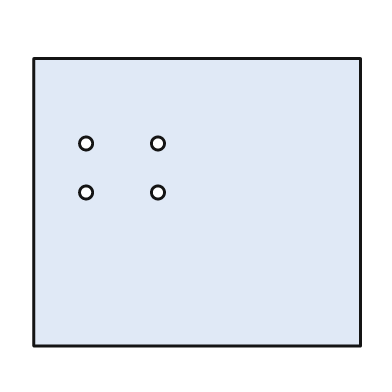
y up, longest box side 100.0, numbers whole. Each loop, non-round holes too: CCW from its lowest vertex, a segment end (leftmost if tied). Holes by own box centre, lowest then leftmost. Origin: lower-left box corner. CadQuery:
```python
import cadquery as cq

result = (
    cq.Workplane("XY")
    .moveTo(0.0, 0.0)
    .lineTo(100.0, 0.0)
    .lineTo(100.0, 88.0)
    .lineTo(0.0, 88.0)
    .close()
    .moveTo(16.0, 47.0)
    .circle(2.0)
    .moveTo(38.0, 47.0)
    .circle(2.0)
    .moveTo(16.0, 62.0)
    .circle(2.0)
    .moveTo(38.0, 62.0)
    .circle(2.0)
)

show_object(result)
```